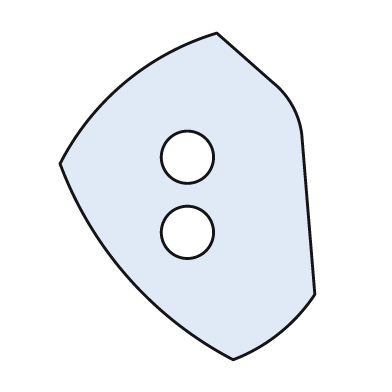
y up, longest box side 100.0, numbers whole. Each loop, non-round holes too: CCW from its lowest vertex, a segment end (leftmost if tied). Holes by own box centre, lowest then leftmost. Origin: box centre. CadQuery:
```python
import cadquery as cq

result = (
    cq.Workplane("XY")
    .moveTo(14.0, -50.0)
    .threePointArc((28.0, -42.0), (39.0, -30.0))
    .lineTo(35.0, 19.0)
    .threePointArc((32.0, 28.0), (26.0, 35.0))
    .lineTo(9.0, 50.0)
    .threePointArc((-19.0, 35.0), (-39.0, 10.0))
    .threePointArc((-18.0, -25.0), (14.0, -50.0))
    .close()
    .moveTo(0.0, -11.0)
    .circle(8.0)
    .moveTo(0.0, 12.0)
    .circle(8.0)
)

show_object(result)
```